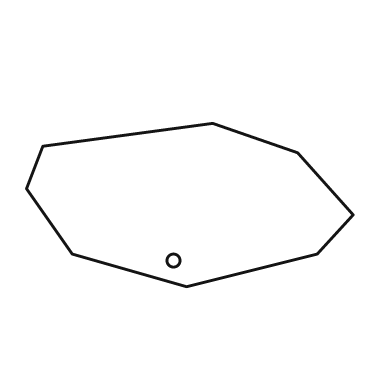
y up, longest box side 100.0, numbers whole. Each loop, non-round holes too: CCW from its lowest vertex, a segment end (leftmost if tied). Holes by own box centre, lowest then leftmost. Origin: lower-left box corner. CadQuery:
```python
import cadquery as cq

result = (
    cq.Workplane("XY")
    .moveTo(49.0, 0.0)
    .lineTo(89.0, 10.0)
    .lineTo(100.0, 22.0)
    .lineTo(83.0, 41.0)
    .lineTo(57.0, 50.0)
    .lineTo(5.0, 43.0)
    .lineTo(0.0, 30.0)
    .lineTo(14.0, 10.0)
    .close()
    .moveTo(45.0, 8.0)
    .circle(2.0)
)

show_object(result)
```